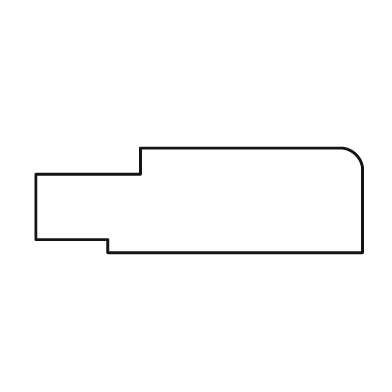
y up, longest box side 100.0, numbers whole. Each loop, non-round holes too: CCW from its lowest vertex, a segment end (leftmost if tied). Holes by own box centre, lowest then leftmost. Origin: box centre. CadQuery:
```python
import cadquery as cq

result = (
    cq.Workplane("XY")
    .moveTo(-28.0, -16.0)
    .lineTo(50.0, -16.0)
    .lineTo(50.0, 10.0)
    .threePointArc((48.0, 14.0), (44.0, 16.0))
    .lineTo(-18.0, 16.0)
    .lineTo(-18.0, 8.0)
    .lineTo(-50.0, 8.0)
    .lineTo(-50.0, -12.0)
    .lineTo(-28.0, -12.0)
    .close()
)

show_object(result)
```